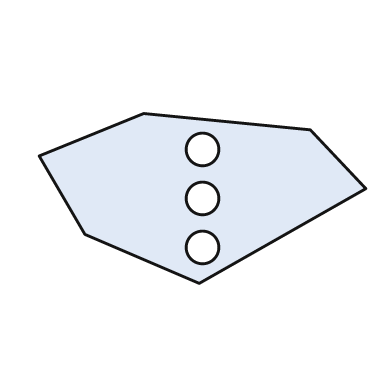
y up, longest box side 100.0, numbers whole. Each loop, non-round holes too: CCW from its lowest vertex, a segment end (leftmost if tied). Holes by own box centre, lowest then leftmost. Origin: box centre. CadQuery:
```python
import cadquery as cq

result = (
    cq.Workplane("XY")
    .moveTo(-1.0, -26.0)
    .lineTo(50.0, 3.0)
    .lineTo(33.0, 21.0)
    .lineTo(-18.0, 26.0)
    .lineTo(-50.0, 13.0)
    .lineTo(-36.0, -11.0)
    .close()
    .moveTo(0.0, -15.0)
    .circle(5.0)
    .moveTo(0.0, 0.0)
    .circle(5.0)
    .moveTo(0.0, 15.0)
    .circle(5.0)
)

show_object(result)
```